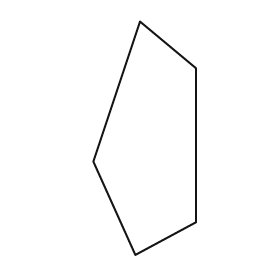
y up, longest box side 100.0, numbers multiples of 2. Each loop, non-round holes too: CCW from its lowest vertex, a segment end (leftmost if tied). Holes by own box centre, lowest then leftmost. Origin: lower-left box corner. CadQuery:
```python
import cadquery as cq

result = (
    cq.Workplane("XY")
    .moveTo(18.0, 0.0)
    .lineTo(44.0, 14.0)
    .lineTo(44.0, 80.0)
    .lineTo(20.0, 100.0)
    .lineTo(0.0, 40.0)
    .close()
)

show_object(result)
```